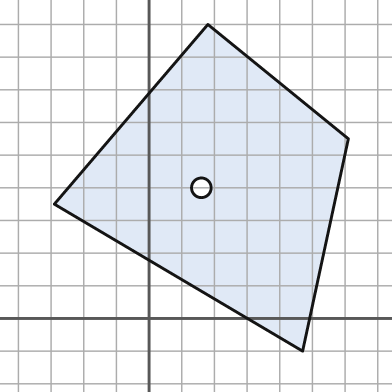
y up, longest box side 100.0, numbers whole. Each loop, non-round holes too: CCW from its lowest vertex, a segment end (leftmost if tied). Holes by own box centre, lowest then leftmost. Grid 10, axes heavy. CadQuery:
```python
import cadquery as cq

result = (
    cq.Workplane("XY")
    .moveTo(47.0, -10.0)
    .lineTo(61.0, 55.0)
    .lineTo(18.0, 90.0)
    .lineTo(-29.0, 35.0)
    .close()
    .moveTo(16.0, 40.0)
    .circle(3.0)
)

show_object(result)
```